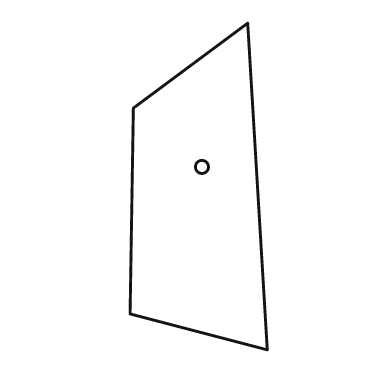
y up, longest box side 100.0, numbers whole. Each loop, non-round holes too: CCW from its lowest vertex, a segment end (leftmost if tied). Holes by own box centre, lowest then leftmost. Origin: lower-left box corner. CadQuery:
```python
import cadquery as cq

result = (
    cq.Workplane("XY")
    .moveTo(42.0, 0.0)
    .lineTo(36.0, 100.0)
    .lineTo(1.0, 74.0)
    .lineTo(0.0, 11.0)
    .close()
    .moveTo(22.0, 56.0)
    .circle(2.0)
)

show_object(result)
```